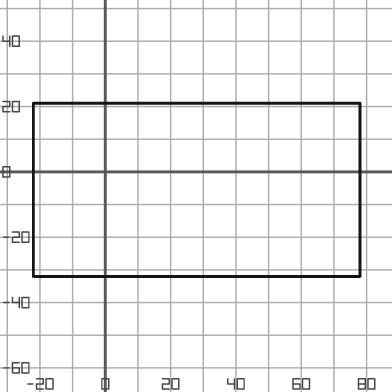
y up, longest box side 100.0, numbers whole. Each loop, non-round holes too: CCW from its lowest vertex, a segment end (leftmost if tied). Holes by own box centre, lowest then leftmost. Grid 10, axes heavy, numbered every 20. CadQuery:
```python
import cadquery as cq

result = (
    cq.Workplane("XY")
    .moveTo(-22.0, -32.0)
    .lineTo(78.0, -32.0)
    .lineTo(78.0, 21.0)
    .lineTo(-22.0, 21.0)
    .close()
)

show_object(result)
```